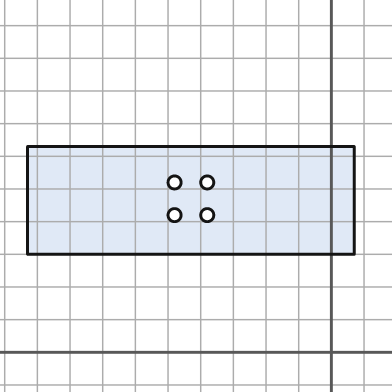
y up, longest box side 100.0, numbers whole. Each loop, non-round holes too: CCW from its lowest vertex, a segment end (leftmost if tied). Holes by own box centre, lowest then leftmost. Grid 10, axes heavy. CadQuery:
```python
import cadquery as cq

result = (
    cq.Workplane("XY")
    .moveTo(-93.0, 30.0)
    .lineTo(7.0, 30.0)
    .lineTo(7.0, 63.0)
    .lineTo(-93.0, 63.0)
    .close()
    .moveTo(-48.0, 42.0)
    .circle(2.0)
    .moveTo(-38.0, 42.0)
    .circle(2.0)
    .moveTo(-48.0, 52.0)
    .circle(2.0)
    .moveTo(-38.0, 52.0)
    .circle(2.0)
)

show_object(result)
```